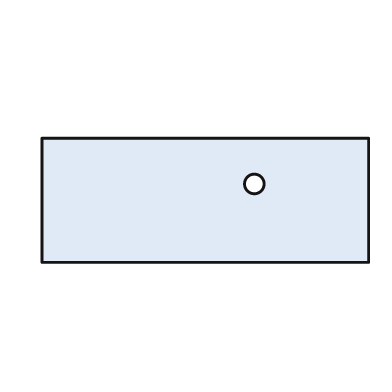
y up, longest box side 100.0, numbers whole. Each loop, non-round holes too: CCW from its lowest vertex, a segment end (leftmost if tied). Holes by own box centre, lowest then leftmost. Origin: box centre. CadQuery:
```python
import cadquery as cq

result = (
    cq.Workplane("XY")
    .moveTo(-50.0, -19.0)
    .lineTo(50.0, -19.0)
    .lineTo(50.0, 19.0)
    .lineTo(-50.0, 19.0)
    .close()
    .moveTo(15.0, 5.0)
    .circle(3.0)
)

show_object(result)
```